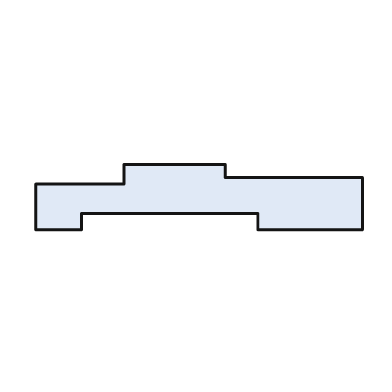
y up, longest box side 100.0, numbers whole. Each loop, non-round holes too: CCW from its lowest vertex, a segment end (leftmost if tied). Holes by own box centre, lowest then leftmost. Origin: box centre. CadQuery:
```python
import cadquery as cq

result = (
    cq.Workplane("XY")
    .moveTo(-50.0, -10.0)
    .lineTo(-36.0, -10.0)
    .lineTo(-36.0, -5.0)
    .lineTo(18.0, -5.0)
    .lineTo(18.0, -10.0)
    .lineTo(50.0, -10.0)
    .lineTo(50.0, 6.0)
    .lineTo(8.0, 6.0)
    .lineTo(8.0, 10.0)
    .lineTo(-23.0, 10.0)
    .lineTo(-23.0, 4.0)
    .lineTo(-50.0, 4.0)
    .close()
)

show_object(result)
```